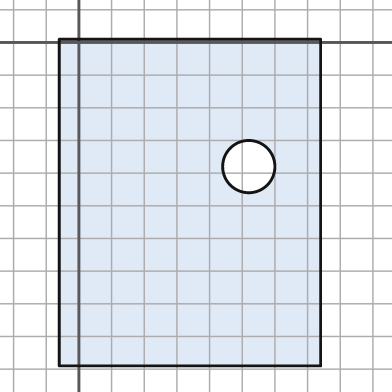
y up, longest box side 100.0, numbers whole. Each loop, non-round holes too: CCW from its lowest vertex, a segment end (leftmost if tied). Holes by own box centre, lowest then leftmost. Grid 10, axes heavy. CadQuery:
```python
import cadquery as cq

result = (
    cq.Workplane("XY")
    .moveTo(-6.0, -99.0)
    .lineTo(74.0, -99.0)
    .lineTo(74.0, 1.0)
    .lineTo(-6.0, 1.0)
    .close()
    .moveTo(52.0, -38.0)
    .circle(8.0)
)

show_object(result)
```